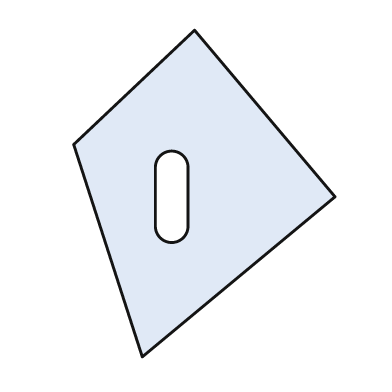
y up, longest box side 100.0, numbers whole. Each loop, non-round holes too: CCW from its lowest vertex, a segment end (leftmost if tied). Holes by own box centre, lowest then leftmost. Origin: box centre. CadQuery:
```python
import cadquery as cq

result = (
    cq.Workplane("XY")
    .moveTo(-19.0, -50.0)
    .lineTo(40.0, -1.0)
    .lineTo(-3.0, 50.0)
    .lineTo(-40.0, 15.0)
    .close()
    .moveTo(-15.0, -10.0)
    .threePointArc((-10.0, -15.0), (-5.0, -10.0))
    .lineTo(-5.0, 8.0)
    .threePointArc((-10.0, 13.0), (-15.0, 8.0))
    .close()
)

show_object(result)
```